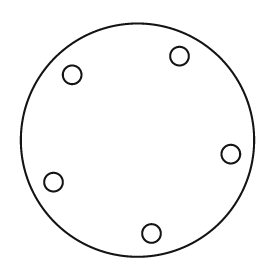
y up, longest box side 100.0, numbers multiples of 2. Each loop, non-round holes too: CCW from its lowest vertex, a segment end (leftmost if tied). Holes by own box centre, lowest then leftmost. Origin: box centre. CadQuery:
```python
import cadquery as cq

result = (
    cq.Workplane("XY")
    .moveTo(0.0, 0.0)
    .circle(50.0)
    .moveTo(6.0, -40.0)
    .circle(4.0)
    .moveTo(-36.0, -18.0)
    .circle(4.0)
    .moveTo(40.0, -6.0)
    .circle(4.0)
    .moveTo(-28.0, 28.0)
    .circle(4.0)
    .moveTo(18.0, 36.0)
    .circle(4.0)
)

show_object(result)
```